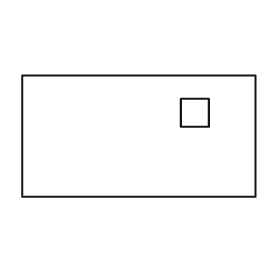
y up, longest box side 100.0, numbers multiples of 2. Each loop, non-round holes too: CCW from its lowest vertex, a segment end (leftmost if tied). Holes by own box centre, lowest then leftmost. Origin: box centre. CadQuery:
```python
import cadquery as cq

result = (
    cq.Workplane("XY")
    .moveTo(-50.0, -26.0)
    .lineTo(50.0, -26.0)
    .lineTo(50.0, 26.0)
    .lineTo(-50.0, 26.0)
    .close()
    .moveTo(18.0, 4.0)
    .lineTo(30.0, 4.0)
    .lineTo(30.0, 16.0)
    .lineTo(18.0, 16.0)
    .close()
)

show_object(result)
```